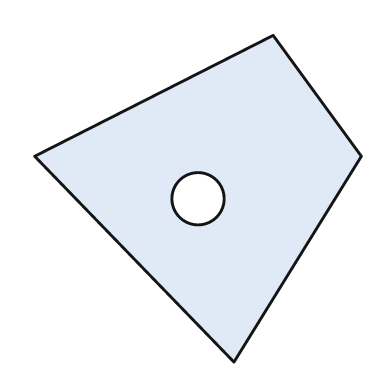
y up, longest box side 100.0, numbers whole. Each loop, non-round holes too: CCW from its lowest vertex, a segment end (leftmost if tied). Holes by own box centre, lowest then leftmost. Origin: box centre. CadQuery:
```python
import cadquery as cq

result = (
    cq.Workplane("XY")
    .moveTo(11.0, -50.0)
    .lineTo(50.0, 13.0)
    .lineTo(23.0, 50.0)
    .lineTo(-50.0, 13.0)
    .close()
    .moveTo(0.0, 0.0)
    .circle(8.0)
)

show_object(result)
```